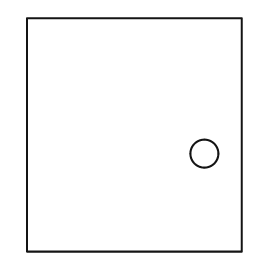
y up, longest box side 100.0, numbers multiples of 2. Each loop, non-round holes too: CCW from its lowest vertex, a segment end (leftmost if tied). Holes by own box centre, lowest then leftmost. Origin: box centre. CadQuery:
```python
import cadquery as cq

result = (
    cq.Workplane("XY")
    .moveTo(-46.0, -50.0)
    .lineTo(46.0, -50.0)
    .lineTo(46.0, 50.0)
    .lineTo(-46.0, 50.0)
    .close()
    .moveTo(30.0, -8.0)
    .circle(6.0)
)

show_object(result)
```